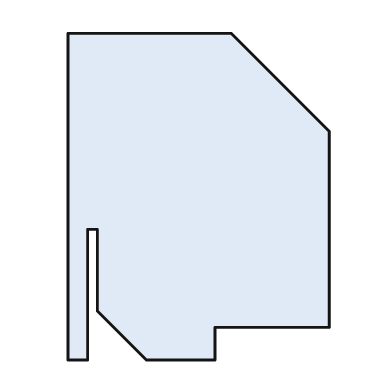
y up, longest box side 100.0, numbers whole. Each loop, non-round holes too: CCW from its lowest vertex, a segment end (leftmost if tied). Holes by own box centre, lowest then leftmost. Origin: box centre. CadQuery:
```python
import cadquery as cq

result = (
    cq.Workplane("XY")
    .moveTo(-40.0, -50.0)
    .lineTo(-34.0, -50.0)
    .lineTo(-34.0, -10.0)
    .lineTo(-31.0, -10.0)
    .lineTo(-31.0, -35.0)
    .lineTo(-16.0, -50.0)
    .lineTo(5.0, -50.0)
    .lineTo(5.0, -40.0)
    .lineTo(40.0, -40.0)
    .lineTo(40.0, 20.0)
    .lineTo(10.0, 50.0)
    .lineTo(-40.0, 50.0)
    .close()
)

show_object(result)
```